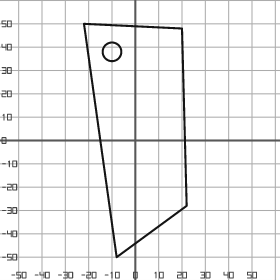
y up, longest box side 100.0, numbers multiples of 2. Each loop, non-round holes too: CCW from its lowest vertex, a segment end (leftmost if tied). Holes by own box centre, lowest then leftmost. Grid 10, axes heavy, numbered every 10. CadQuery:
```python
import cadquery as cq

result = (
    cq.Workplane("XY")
    .moveTo(-8.0, -50.0)
    .lineTo(22.0, -28.0)
    .lineTo(20.0, 48.0)
    .lineTo(-22.0, 50.0)
    .close()
    .moveTo(-10.0, 38.0)
    .circle(4.0)
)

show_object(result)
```